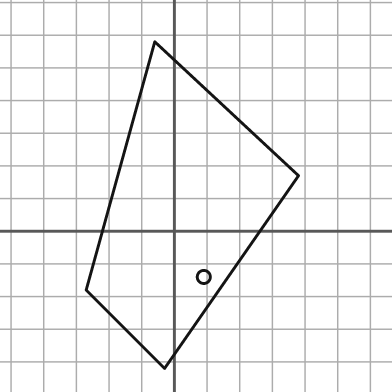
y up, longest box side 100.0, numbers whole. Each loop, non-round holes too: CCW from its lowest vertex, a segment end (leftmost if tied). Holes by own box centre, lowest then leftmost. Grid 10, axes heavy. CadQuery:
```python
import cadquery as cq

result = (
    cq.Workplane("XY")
    .moveTo(-3.0, -42.0)
    .lineTo(38.0, 17.0)
    .lineTo(-6.0, 58.0)
    .lineTo(-27.0, -18.0)
    .close()
    .moveTo(9.0, -14.0)
    .circle(2.0)
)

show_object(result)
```